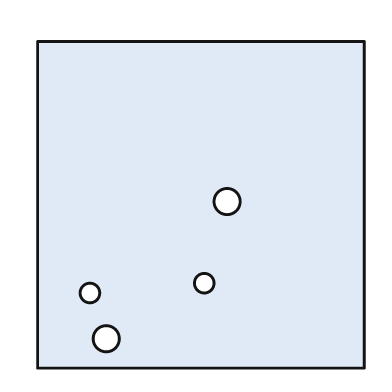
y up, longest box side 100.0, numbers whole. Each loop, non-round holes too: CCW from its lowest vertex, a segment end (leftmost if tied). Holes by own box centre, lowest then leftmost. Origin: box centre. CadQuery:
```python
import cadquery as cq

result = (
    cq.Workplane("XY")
    .moveTo(-50.0, -50.0)
    .lineTo(50.0, -50.0)
    .lineTo(50.0, 50.0)
    .lineTo(-50.0, 50.0)
    .close()
    .moveTo(-29.0, -41.0)
    .circle(4.0)
    .moveTo(-34.0, -27.0)
    .circle(3.0)
    .moveTo(1.0, -24.0)
    .circle(3.0)
    .moveTo(8.0, 1.0)
    .circle(4.0)
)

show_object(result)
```